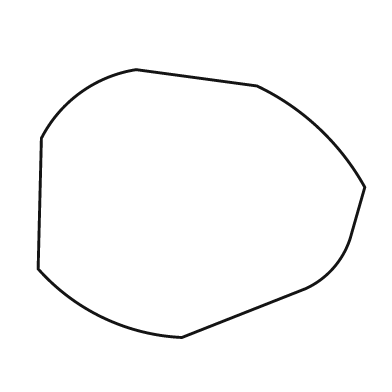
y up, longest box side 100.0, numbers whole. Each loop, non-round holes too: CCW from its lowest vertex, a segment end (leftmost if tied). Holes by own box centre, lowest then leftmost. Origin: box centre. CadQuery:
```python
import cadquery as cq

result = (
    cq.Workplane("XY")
    .moveTo(-6.0, -41.0)
    .lineTo(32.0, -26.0)
    .threePointArc((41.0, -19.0), (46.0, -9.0))
    .lineTo(50.0, 5.0)
    .threePointArc((36.0, 23.0), (17.0, 36.0))
    .lineTo(-20.0, 41.0)
    .threePointArc((-37.0, 34.0), (-49.0, 20.0))
    .lineTo(-50.0, -20.0)
    .threePointArc((-30.0, -35.0), (-6.0, -41.0))
    .close()
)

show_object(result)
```